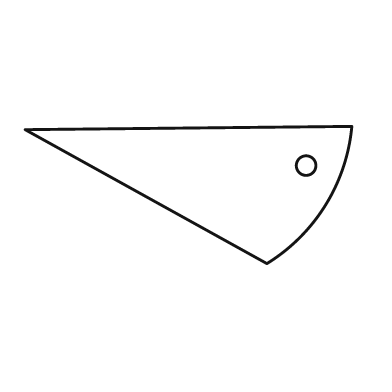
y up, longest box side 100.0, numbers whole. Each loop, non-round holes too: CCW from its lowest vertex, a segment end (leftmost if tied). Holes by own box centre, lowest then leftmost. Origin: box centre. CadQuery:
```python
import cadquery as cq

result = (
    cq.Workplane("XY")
    .moveTo(24.0, -21.0)
    .threePointArc((42.0, -3.0), (50.0, 21.0))
    .lineTo(-50.0, 20.0)
    .close()
    .moveTo(36.0, 9.0)
    .circle(3.0)
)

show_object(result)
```